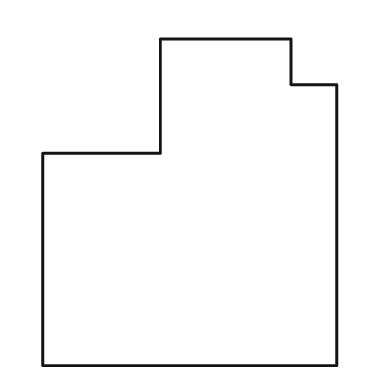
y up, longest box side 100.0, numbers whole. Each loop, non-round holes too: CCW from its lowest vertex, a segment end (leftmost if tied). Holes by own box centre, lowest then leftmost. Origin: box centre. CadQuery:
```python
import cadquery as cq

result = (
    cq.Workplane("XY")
    .moveTo(-45.0, -50.0)
    .lineTo(45.0, -50.0)
    .lineTo(45.0, 36.0)
    .lineTo(31.0, 36.0)
    .lineTo(31.0, 50.0)
    .lineTo(-9.0, 50.0)
    .lineTo(-9.0, 15.0)
    .lineTo(-45.0, 15.0)
    .close()
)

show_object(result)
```